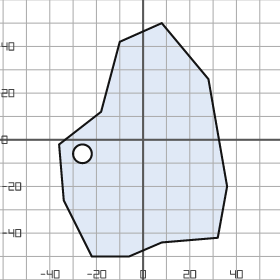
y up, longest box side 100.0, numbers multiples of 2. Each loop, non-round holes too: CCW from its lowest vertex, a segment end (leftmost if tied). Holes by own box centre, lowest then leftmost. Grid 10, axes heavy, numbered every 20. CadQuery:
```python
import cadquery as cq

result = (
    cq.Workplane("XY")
    .moveTo(-22.0, -50.0)
    .lineTo(-6.0, -50.0)
    .lineTo(8.0, -44.0)
    .lineTo(32.0, -42.0)
    .lineTo(36.0, -20.0)
    .lineTo(28.0, 26.0)
    .lineTo(8.0, 50.0)
    .lineTo(-10.0, 42.0)
    .lineTo(-18.0, 12.0)
    .lineTo(-36.0, -2.0)
    .lineTo(-34.0, -26.0)
    .close()
    .moveTo(-26.0, -6.0)
    .circle(4.0)
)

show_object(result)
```